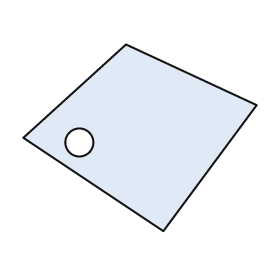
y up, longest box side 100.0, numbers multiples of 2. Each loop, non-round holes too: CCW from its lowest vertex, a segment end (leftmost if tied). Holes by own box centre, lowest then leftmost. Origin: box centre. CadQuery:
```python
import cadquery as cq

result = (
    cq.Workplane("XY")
    .moveTo(10.0, -40.0)
    .lineTo(50.0, 14.0)
    .lineTo(-6.0, 40.0)
    .lineTo(-50.0, 0.0)
    .close()
    .moveTo(-26.0, -2.0)
    .circle(6.0)
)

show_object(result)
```